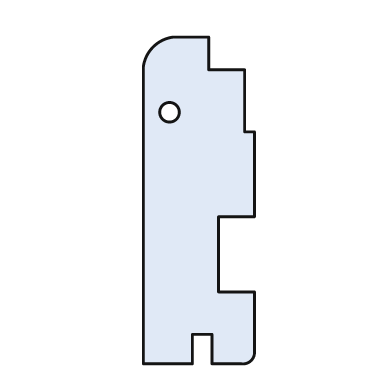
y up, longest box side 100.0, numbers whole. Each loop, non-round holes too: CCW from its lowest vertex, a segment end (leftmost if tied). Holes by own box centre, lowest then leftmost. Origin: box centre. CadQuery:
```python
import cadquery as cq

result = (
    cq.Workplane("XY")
    .moveTo(-17.0, -50.0)
    .lineTo(-2.0, -50.0)
    .lineTo(-2.0, -41.0)
    .lineTo(4.0, -41.0)
    .lineTo(4.0, -50.0)
    .lineTo(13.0, -50.0)
    .threePointArc((16.0, -49.0), (17.0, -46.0))
    .lineTo(17.0, -28.0)
    .lineTo(6.0, -28.0)
    .lineTo(6.0, -5.0)
    .lineTo(17.0, -5.0)
    .lineTo(17.0, 21.0)
    .lineTo(14.0, 21.0)
    .lineTo(14.0, 40.0)
    .lineTo(3.0, 40.0)
    .lineTo(3.0, 50.0)
    .lineTo(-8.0, 50.0)
    .threePointArc((-14.0, 47.0), (-17.0, 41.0))
    .close()
    .moveTo(-9.0, 27.0)
    .circle(3.0)
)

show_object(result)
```